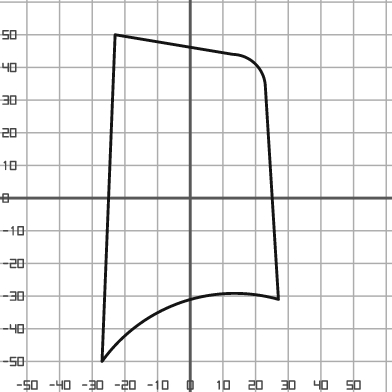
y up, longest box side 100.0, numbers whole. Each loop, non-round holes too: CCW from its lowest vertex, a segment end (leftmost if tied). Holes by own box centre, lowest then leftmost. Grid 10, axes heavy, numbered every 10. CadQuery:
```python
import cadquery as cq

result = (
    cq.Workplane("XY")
    .moveTo(-27.0, -50.0)
    .threePointArc((-3.0, -32.0), (27.0, -31.0))
    .lineTo(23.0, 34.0)
    .threePointArc((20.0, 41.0), (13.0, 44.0))
    .lineTo(-23.0, 50.0)
    .close()
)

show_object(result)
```